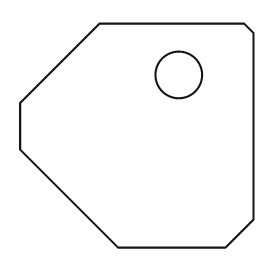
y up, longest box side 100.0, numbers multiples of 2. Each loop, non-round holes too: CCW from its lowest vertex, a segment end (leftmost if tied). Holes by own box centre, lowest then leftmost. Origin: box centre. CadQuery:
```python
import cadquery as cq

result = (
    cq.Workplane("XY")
    .moveTo(-8.0, -48.0)
    .lineTo(38.0, -48.0)
    .lineTo(50.0, -36.0)
    .lineTo(50.0, 44.0)
    .lineTo(46.0, 48.0)
    .lineTo(-16.0, 48.0)
    .lineTo(-50.0, 14.0)
    .lineTo(-50.0, -6.0)
    .close()
    .moveTo(18.0, 26.0)
    .circle(10.0)
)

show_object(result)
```